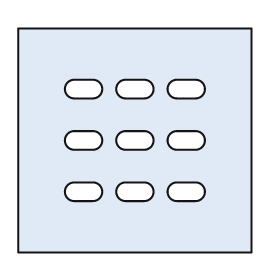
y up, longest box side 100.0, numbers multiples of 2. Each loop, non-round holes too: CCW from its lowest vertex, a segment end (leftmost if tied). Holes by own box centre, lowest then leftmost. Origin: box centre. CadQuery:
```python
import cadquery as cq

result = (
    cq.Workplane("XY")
    .moveTo(-50.0, -48.0)
    .lineTo(50.0, -48.0)
    .lineTo(50.0, 48.0)
    .lineTo(-50.0, 48.0)
    .close()
    .moveTo(-26.0, -26.0)
    .lineTo(-18.0, -26.0)
    .threePointArc((-14.0, -22.0), (-18.0, -18.0))
    .lineTo(-26.0, -18.0)
    .threePointArc((-30.0, -22.0), (-26.0, -26.0))
    .close()
    .moveTo(-4.0, -26.0)
    .lineTo(4.0, -26.0)
    .threePointArc((8.0, -22.0), (4.0, -18.0))
    .lineTo(-4.0, -18.0)
    .threePointArc((-8.0, -22.0), (-4.0, -26.0))
    .close()
    .moveTo(18.0, -26.0)
    .lineTo(26.0, -26.0)
    .threePointArc((30.0, -22.0), (26.0, -18.0))
    .lineTo(18.0, -18.0)
    .threePointArc((14.0, -22.0), (18.0, -26.0))
    .close()
    .moveTo(-26.0, -4.0)
    .lineTo(-18.0, -4.0)
    .threePointArc((-14.0, 0.0), (-18.0, 4.0))
    .lineTo(-26.0, 4.0)
    .threePointArc((-30.0, 0.0), (-26.0, -4.0))
    .close()
    .moveTo(-4.0, -4.0)
    .lineTo(4.0, -4.0)
    .threePointArc((8.0, 0.0), (4.0, 4.0))
    .lineTo(-4.0, 4.0)
    .threePointArc((-8.0, 0.0), (-4.0, -4.0))
    .close()
    .moveTo(18.0, -4.0)
    .lineTo(26.0, -4.0)
    .threePointArc((30.0, 0.0), (26.0, 4.0))
    .lineTo(18.0, 4.0)
    .threePointArc((14.0, 0.0), (18.0, -4.0))
    .close()
    .moveTo(-26.0, 18.0)
    .lineTo(-18.0, 18.0)
    .threePointArc((-14.0, 22.0), (-18.0, 26.0))
    .lineTo(-26.0, 26.0)
    .threePointArc((-30.0, 22.0), (-26.0, 18.0))
    .close()
    .moveTo(-4.0, 18.0)
    .lineTo(4.0, 18.0)
    .threePointArc((8.0, 22.0), (4.0, 26.0))
    .lineTo(-4.0, 26.0)
    .threePointArc((-8.0, 22.0), (-4.0, 18.0))
    .close()
    .moveTo(18.0, 18.0)
    .lineTo(26.0, 18.0)
    .threePointArc((30.0, 22.0), (26.0, 26.0))
    .lineTo(18.0, 26.0)
    .threePointArc((14.0, 22.0), (18.0, 18.0))
    .close()
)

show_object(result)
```